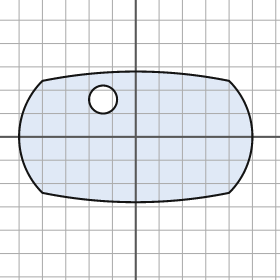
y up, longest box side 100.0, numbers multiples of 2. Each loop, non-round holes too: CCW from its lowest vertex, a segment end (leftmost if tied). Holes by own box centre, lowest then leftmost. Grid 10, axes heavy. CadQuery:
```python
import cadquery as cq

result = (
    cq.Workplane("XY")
    .moveTo(-40.0, -24.0)
    .threePointArc((0.0, -28.0), (40.0, -24.0))
    .threePointArc((50.0, 0.0), (40.0, 24.0))
    .threePointArc((0.0, 28.0), (-40.0, 24.0))
    .threePointArc((-50.0, 0.0), (-40.0, -24.0))
    .close()
    .moveTo(-14.0, 16.0)
    .circle(6.0)
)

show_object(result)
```